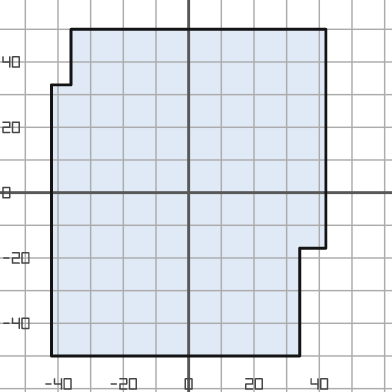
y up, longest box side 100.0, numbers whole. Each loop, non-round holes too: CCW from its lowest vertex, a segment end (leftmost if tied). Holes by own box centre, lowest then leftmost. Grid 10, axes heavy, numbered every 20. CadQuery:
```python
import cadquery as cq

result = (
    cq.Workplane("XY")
    .moveTo(-42.0, -50.0)
    .lineTo(34.0, -50.0)
    .lineTo(34.0, -17.0)
    .lineTo(42.0, -17.0)
    .lineTo(42.0, 50.0)
    .lineTo(-36.0, 50.0)
    .lineTo(-36.0, 33.0)
    .lineTo(-42.0, 33.0)
    .close()
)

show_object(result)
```